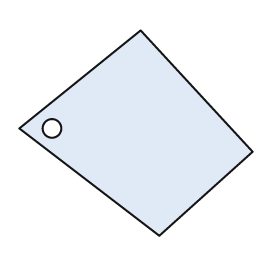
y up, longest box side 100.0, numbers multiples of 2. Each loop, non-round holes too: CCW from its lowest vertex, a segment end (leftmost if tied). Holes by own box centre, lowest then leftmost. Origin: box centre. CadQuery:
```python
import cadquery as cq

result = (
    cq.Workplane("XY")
    .moveTo(10.0, -44.0)
    .lineTo(50.0, -8.0)
    .lineTo(2.0, 44.0)
    .lineTo(-50.0, 2.0)
    .close()
    .moveTo(-36.0, 2.0)
    .circle(4.0)
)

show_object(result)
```